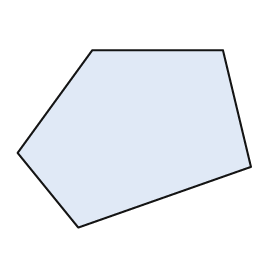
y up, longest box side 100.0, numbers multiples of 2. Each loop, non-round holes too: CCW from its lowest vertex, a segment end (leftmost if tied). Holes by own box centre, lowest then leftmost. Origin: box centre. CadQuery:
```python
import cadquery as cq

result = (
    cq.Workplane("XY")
    .moveTo(-24.0, -38.0)
    .lineTo(50.0, -12.0)
    .lineTo(38.0, 38.0)
    .lineTo(-18.0, 38.0)
    .lineTo(-50.0, -6.0)
    .close()
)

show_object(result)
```